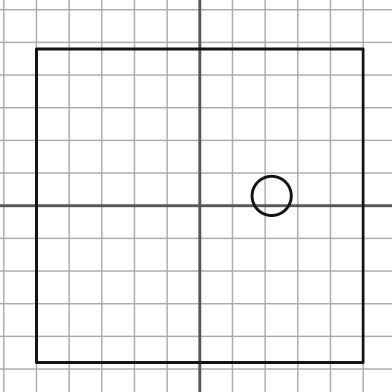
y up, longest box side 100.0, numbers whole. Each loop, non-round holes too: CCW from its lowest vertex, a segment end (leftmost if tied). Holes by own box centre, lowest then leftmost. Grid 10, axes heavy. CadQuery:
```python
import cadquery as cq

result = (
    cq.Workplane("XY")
    .moveTo(-50.0, -48.0)
    .lineTo(50.0, -48.0)
    .lineTo(50.0, 48.0)
    .lineTo(-50.0, 48.0)
    .close()
    .moveTo(22.0, 3.0)
    .circle(6.0)
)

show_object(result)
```